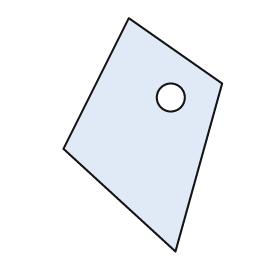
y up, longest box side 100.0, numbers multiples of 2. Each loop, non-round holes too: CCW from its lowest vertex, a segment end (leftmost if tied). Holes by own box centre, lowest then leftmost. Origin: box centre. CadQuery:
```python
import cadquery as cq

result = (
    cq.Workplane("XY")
    .moveTo(14.0, -50.0)
    .lineTo(34.0, 22.0)
    .lineTo(-6.0, 50.0)
    .lineTo(-34.0, -6.0)
    .close()
    .moveTo(12.0, 16.0)
    .circle(6.0)
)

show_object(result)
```